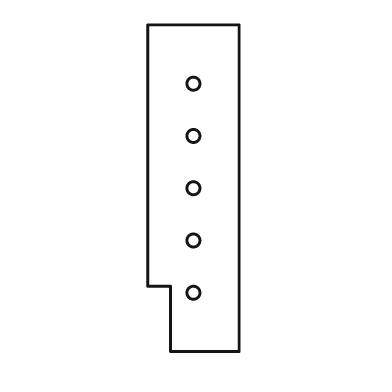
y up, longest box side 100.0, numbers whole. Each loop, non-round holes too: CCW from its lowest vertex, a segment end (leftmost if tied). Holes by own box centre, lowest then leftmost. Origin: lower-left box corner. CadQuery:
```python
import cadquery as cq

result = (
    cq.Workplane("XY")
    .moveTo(7.0, 0.0)
    .lineTo(28.0, 0.0)
    .lineTo(28.0, 100.0)
    .lineTo(0.0, 100.0)
    .lineTo(0.0, 20.0)
    .lineTo(7.0, 20.0)
    .close()
    .moveTo(14.0, 18.0)
    .circle(2.0)
    .moveTo(14.0, 34.0)
    .circle(2.0)
    .moveTo(14.0, 50.0)
    .circle(2.0)
    .moveTo(14.0, 66.0)
    .circle(2.0)
    .moveTo(14.0, 82.0)
    .circle(2.0)
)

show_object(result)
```